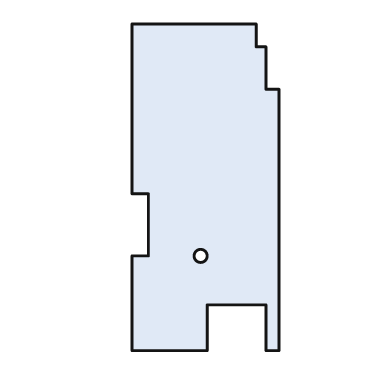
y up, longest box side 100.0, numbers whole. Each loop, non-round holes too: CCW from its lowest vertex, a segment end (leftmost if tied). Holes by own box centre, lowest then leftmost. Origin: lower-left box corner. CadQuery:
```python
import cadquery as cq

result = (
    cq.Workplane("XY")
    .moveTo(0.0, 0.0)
    .lineTo(23.0, 0.0)
    .lineTo(23.0, 14.0)
    .lineTo(41.0, 14.0)
    .lineTo(41.0, 0.0)
    .lineTo(45.0, 0.0)
    .lineTo(45.0, 80.0)
    .lineTo(41.0, 80.0)
    .lineTo(41.0, 93.0)
    .lineTo(38.0, 93.0)
    .lineTo(38.0, 100.0)
    .lineTo(0.0, 100.0)
    .lineTo(0.0, 48.0)
    .lineTo(5.0, 48.0)
    .lineTo(5.0, 29.0)
    .lineTo(0.0, 29.0)
    .close()
    .moveTo(21.0, 29.0)
    .circle(2.0)
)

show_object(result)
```